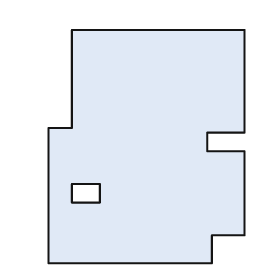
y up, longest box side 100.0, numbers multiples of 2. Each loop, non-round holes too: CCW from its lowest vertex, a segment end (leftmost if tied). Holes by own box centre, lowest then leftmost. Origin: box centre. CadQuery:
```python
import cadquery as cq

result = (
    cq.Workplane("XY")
    .moveTo(-42.0, -50.0)
    .lineTo(28.0, -50.0)
    .lineTo(28.0, -38.0)
    .lineTo(42.0, -38.0)
    .lineTo(42.0, -2.0)
    .lineTo(26.0, -2.0)
    .lineTo(26.0, 6.0)
    .lineTo(42.0, 6.0)
    .lineTo(42.0, 50.0)
    .lineTo(-32.0, 50.0)
    .lineTo(-32.0, 8.0)
    .lineTo(-42.0, 8.0)
    .close()
    .moveTo(-32.0, -24.0)
    .lineTo(-20.0, -24.0)
    .lineTo(-20.0, -16.0)
    .lineTo(-32.0, -16.0)
    .close()
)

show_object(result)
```